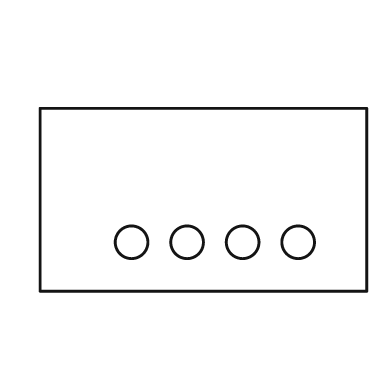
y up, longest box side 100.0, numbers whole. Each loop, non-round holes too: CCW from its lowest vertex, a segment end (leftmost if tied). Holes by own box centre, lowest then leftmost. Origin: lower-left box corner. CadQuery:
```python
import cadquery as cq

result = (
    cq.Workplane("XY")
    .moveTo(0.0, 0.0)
    .lineTo(100.0, 0.0)
    .lineTo(100.0, 56.0)
    .lineTo(0.0, 56.0)
    .close()
    .moveTo(28.0, 15.0)
    .circle(5.0)
    .moveTo(45.0, 15.0)
    .circle(5.0)
    .moveTo(62.0, 15.0)
    .circle(5.0)
    .moveTo(79.0, 15.0)
    .circle(5.0)
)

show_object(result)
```